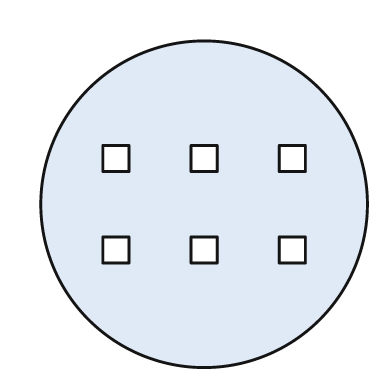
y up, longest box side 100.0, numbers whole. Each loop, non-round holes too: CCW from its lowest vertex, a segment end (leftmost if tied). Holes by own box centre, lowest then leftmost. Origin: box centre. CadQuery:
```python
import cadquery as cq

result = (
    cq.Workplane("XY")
    .moveTo(0.0, 0.0)
    .circle(50.0)
    .moveTo(-31.0, -18.0)
    .lineTo(-23.0, -18.0)
    .lineTo(-23.0, -10.0)
    .lineTo(-31.0, -10.0)
    .close()
    .moveTo(-4.0, -18.0)
    .lineTo(4.0, -18.0)
    .lineTo(4.0, -10.0)
    .lineTo(-4.0, -10.0)
    .close()
    .moveTo(23.0, -18.0)
    .lineTo(31.0, -18.0)
    .lineTo(31.0, -10.0)
    .lineTo(23.0, -10.0)
    .close()
    .moveTo(-31.0, 10.0)
    .lineTo(-23.0, 10.0)
    .lineTo(-23.0, 18.0)
    .lineTo(-31.0, 18.0)
    .close()
    .moveTo(-4.0, 10.0)
    .lineTo(4.0, 10.0)
    .lineTo(4.0, 18.0)
    .lineTo(-4.0, 18.0)
    .close()
    .moveTo(23.0, 10.0)
    .lineTo(31.0, 10.0)
    .lineTo(31.0, 18.0)
    .lineTo(23.0, 18.0)
    .close()
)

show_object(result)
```